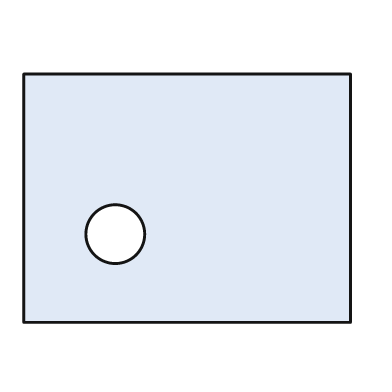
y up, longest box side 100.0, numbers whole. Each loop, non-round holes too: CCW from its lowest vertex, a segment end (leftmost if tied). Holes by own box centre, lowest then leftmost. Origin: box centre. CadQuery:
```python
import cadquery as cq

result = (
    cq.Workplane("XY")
    .moveTo(-50.0, -38.0)
    .lineTo(50.0, -38.0)
    .lineTo(50.0, 38.0)
    .lineTo(-50.0, 38.0)
    .close()
    .moveTo(-22.0, -11.0)
    .circle(9.0)
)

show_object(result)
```